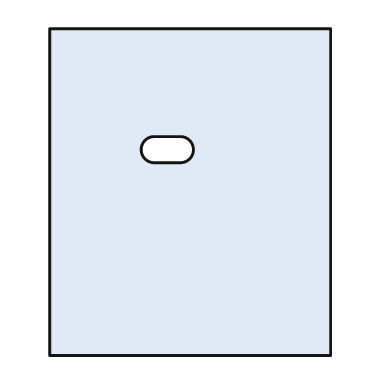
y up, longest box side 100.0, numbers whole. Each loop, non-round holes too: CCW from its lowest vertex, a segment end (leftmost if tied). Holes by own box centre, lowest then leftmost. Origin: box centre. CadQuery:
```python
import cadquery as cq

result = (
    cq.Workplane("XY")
    .moveTo(-43.0, -50.0)
    .lineTo(43.0, -50.0)
    .lineTo(43.0, 50.0)
    .lineTo(-43.0, 50.0)
    .close()
    .moveTo(-11.0, 9.0)
    .lineTo(-3.0, 9.0)
    .threePointArc((1.0, 13.0), (-3.0, 17.0))
    .lineTo(-11.0, 17.0)
    .threePointArc((-15.0, 13.0), (-11.0, 9.0))
    .close()
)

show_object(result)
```